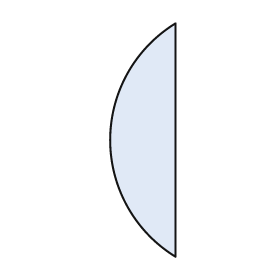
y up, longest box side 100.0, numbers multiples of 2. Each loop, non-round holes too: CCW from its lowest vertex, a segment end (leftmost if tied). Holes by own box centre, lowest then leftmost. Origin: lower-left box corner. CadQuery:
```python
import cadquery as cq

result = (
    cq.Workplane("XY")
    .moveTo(28.0, 0.0)
    .lineTo(28.0, 100.0)
    .threePointArc((0.0, 50.0), (28.0, 0.0))
    .close()
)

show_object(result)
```